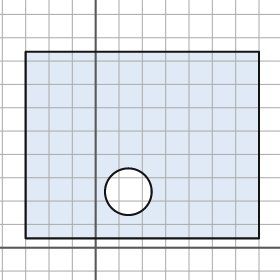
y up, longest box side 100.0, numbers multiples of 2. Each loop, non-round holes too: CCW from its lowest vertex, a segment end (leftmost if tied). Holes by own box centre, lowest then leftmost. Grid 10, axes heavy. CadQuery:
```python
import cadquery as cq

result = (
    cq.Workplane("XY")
    .moveTo(-30.0, 4.0)
    .lineTo(70.0, 4.0)
    .lineTo(70.0, 84.0)
    .lineTo(-30.0, 84.0)
    .close()
    .moveTo(14.0, 24.0)
    .circle(10.0)
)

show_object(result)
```